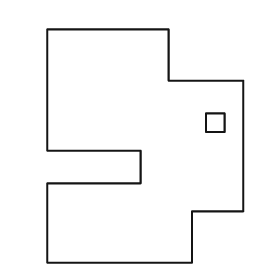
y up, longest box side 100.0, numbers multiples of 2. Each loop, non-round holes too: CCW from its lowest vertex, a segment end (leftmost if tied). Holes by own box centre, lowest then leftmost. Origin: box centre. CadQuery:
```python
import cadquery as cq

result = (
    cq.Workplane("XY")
    .moveTo(-42.0, -50.0)
    .lineTo(20.0, -50.0)
    .lineTo(20.0, -28.0)
    .lineTo(42.0, -28.0)
    .lineTo(42.0, 28.0)
    .lineTo(10.0, 28.0)
    .lineTo(10.0, 50.0)
    .lineTo(-42.0, 50.0)
    .lineTo(-42.0, -2.0)
    .lineTo(-2.0, -2.0)
    .lineTo(-2.0, -16.0)
    .lineTo(-42.0, -16.0)
    .close()
    .moveTo(26.0, 6.0)
    .lineTo(34.0, 6.0)
    .lineTo(34.0, 14.0)
    .lineTo(26.0, 14.0)
    .close()
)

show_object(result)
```